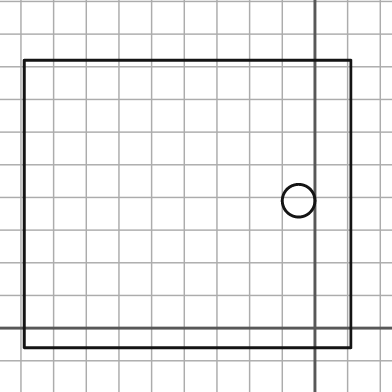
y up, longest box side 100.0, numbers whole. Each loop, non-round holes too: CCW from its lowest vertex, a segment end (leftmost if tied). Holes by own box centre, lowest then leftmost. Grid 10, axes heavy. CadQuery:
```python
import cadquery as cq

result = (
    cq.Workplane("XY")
    .moveTo(-89.0, -6.0)
    .lineTo(11.0, -6.0)
    .lineTo(11.0, 82.0)
    .lineTo(-89.0, 82.0)
    .close()
    .moveTo(-5.0, 39.0)
    .circle(5.0)
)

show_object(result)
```